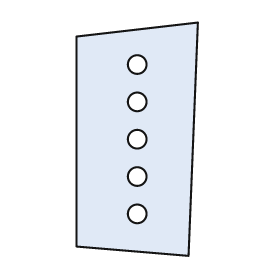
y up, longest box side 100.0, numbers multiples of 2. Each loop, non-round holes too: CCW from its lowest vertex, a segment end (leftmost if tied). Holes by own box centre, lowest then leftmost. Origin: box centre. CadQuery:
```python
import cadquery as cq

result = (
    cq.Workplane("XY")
    .moveTo(22.0, -50.0)
    .lineTo(26.0, 50.0)
    .lineTo(-26.0, 44.0)
    .lineTo(-26.0, -46.0)
    .close()
    .moveTo(0.0, -32.0)
    .circle(4.0)
    .moveTo(0.0, -16.0)
    .circle(4.0)
    .moveTo(0.0, 0.0)
    .circle(4.0)
    .moveTo(0.0, 16.0)
    .circle(4.0)
    .moveTo(0.0, 32.0)
    .circle(4.0)
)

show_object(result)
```